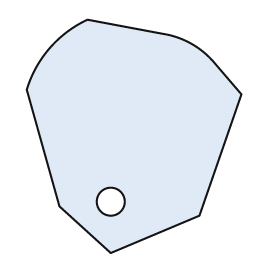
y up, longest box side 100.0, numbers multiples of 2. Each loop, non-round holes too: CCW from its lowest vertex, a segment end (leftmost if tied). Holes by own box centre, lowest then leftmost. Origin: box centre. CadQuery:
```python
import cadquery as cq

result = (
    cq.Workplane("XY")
    .moveTo(-10.0, -50.0)
    .lineTo(28.0, -34.0)
    .lineTo(46.0, 18.0)
    .lineTo(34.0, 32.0)
    .threePointArc((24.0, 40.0), (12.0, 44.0))
    .lineTo(-20.0, 50.0)
    .threePointArc((-36.0, 38.0), (-46.0, 20.0))
    .lineTo(-32.0, -30.0)
    .close()
    .moveTo(-10.0, -28.0)
    .circle(6.0)
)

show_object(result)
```